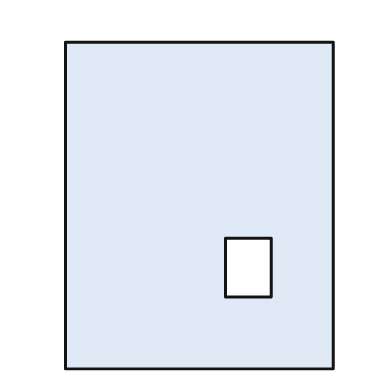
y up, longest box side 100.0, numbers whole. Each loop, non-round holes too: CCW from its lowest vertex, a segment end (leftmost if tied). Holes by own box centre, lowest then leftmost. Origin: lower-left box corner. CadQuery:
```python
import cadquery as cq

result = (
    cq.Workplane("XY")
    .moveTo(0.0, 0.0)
    .lineTo(82.0, 0.0)
    .lineTo(82.0, 100.0)
    .lineTo(0.0, 100.0)
    .close()
    .moveTo(49.0, 22.0)
    .lineTo(63.0, 22.0)
    .lineTo(63.0, 40.0)
    .lineTo(49.0, 40.0)
    .close()
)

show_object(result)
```